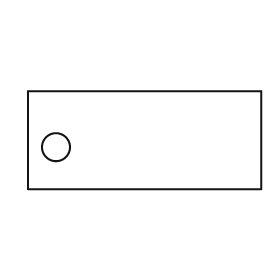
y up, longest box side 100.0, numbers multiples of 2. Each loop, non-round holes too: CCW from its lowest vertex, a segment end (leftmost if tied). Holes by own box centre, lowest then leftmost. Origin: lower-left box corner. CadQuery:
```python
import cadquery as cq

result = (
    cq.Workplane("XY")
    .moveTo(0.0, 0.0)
    .lineTo(100.0, 0.0)
    .lineTo(100.0, 42.0)
    .lineTo(0.0, 42.0)
    .close()
    .moveTo(12.0, 18.0)
    .circle(6.0)
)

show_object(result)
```